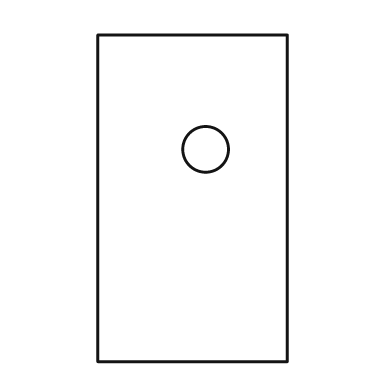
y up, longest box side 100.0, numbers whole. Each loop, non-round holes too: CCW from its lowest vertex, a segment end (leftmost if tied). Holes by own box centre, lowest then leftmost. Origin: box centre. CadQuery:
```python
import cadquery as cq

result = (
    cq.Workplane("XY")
    .moveTo(-29.0, -50.0)
    .lineTo(29.0, -50.0)
    .lineTo(29.0, 50.0)
    .lineTo(-29.0, 50.0)
    .close()
    .moveTo(4.0, 15.0)
    .circle(7.0)
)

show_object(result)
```